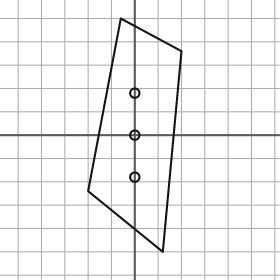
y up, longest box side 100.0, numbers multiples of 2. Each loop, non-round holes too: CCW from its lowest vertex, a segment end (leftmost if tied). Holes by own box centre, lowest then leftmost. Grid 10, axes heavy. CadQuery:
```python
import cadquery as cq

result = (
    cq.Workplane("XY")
    .moveTo(12.0, -50.0)
    .lineTo(20.0, 36.0)
    .lineTo(-6.0, 50.0)
    .lineTo(-20.0, -24.0)
    .close()
    .moveTo(0.0, -18.0)
    .circle(2.0)
    .moveTo(0.0, 0.0)
    .circle(2.0)
    .moveTo(0.0, 18.0)
    .circle(2.0)
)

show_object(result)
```